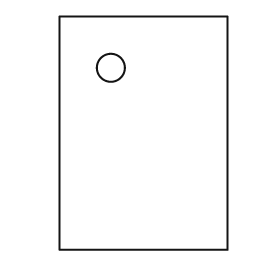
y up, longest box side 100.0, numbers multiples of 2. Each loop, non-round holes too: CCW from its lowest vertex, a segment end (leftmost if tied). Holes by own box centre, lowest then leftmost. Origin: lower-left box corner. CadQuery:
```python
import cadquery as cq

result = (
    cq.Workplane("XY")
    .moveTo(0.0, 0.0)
    .lineTo(72.0, 0.0)
    .lineTo(72.0, 100.0)
    .lineTo(0.0, 100.0)
    .close()
    .moveTo(22.0, 78.0)
    .circle(6.0)
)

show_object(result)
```